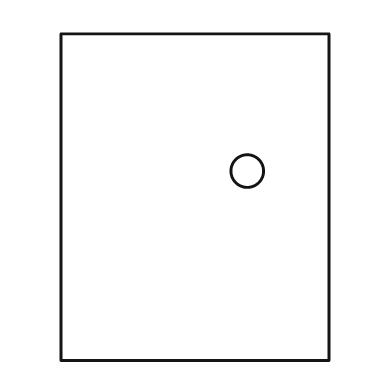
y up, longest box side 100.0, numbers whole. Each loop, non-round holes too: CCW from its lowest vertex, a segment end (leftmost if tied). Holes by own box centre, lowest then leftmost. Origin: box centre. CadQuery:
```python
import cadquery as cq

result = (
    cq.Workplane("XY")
    .moveTo(-41.0, -50.0)
    .lineTo(41.0, -50.0)
    .lineTo(41.0, 50.0)
    .lineTo(-41.0, 50.0)
    .close()
    .moveTo(16.0, 8.0)
    .circle(5.0)
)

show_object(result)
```